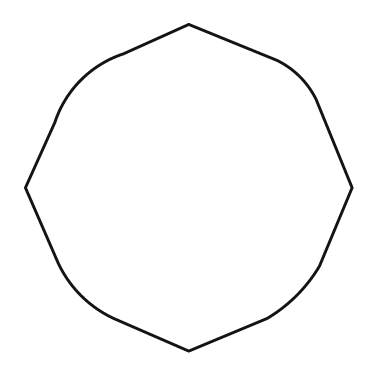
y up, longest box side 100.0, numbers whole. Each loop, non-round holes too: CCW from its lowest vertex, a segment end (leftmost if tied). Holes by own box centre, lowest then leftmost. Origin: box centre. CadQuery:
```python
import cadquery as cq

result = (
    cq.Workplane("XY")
    .moveTo(0.0, -50.0)
    .lineTo(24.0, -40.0)
    .threePointArc((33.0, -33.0), (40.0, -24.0))
    .lineTo(50.0, 0.0)
    .lineTo(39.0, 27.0)
    .threePointArc((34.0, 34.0), (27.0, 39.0))
    .lineTo(0.0, 50.0)
    .lineTo(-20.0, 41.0)
    .threePointArc((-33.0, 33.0), (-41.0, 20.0))
    .lineTo(-50.0, 0.0)
    .lineTo(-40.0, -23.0)
    .threePointArc((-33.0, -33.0), (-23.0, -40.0))
    .close()
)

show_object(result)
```